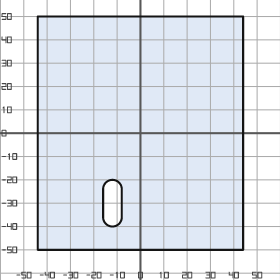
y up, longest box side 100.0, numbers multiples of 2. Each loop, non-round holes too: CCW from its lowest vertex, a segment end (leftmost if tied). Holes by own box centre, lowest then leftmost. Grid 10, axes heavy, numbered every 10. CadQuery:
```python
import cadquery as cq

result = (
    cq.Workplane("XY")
    .moveTo(-44.0, -50.0)
    .lineTo(44.0, -50.0)
    .lineTo(44.0, 50.0)
    .lineTo(-44.0, 50.0)
    .close()
    .moveTo(-16.0, -36.0)
    .threePointArc((-12.0, -40.0), (-8.0, -36.0))
    .lineTo(-8.0, -24.0)
    .threePointArc((-12.0, -20.0), (-16.0, -24.0))
    .close()
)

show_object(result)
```